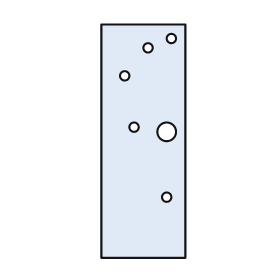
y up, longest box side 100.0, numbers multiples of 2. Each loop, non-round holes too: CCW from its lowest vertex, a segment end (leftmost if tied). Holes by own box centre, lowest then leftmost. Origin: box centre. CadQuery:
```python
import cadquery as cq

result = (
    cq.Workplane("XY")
    .moveTo(-18.0, -50.0)
    .lineTo(18.0, -50.0)
    .lineTo(18.0, 50.0)
    .lineTo(-18.0, 50.0)
    .close()
    .moveTo(10.0, -24.0)
    .circle(2.0)
    .moveTo(10.0, 4.0)
    .circle(4.0)
    .moveTo(-4.0, 6.0)
    .circle(2.0)
    .moveTo(-8.0, 28.0)
    .circle(2.0)
    .moveTo(2.0, 40.0)
    .circle(2.0)
    .moveTo(12.0, 44.0)
    .circle(2.0)
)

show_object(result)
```